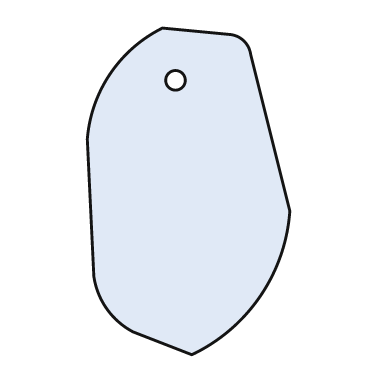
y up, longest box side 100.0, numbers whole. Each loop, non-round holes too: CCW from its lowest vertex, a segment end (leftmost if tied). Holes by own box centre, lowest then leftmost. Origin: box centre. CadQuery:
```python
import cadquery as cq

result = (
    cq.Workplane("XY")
    .moveTo(1.0, -50.0)
    .threePointArc((22.0, -32.0), (31.0, -6.0))
    .lineTo(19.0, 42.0)
    .threePointArc((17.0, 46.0), (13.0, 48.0))
    .lineTo(-8.0, 50.0)
    .threePointArc((-24.0, 36.0), (-31.0, 16.0))
    .lineTo(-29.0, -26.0)
    .threePointArc((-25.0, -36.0), (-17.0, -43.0))
    .close()
    .moveTo(-4.0, 34.0)
    .circle(3.0)
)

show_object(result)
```